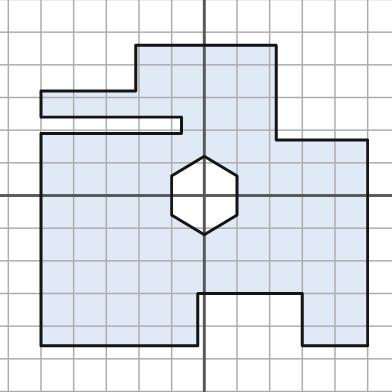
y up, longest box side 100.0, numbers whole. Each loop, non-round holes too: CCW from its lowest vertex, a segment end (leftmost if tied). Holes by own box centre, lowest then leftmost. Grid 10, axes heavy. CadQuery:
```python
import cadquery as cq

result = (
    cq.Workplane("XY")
    .moveTo(-50.0, -46.0)
    .lineTo(-2.0, -46.0)
    .lineTo(-2.0, -30.0)
    .lineTo(30.0, -30.0)
    .lineTo(30.0, -46.0)
    .lineTo(50.0, -46.0)
    .lineTo(50.0, 17.0)
    .lineTo(22.0, 17.0)
    .lineTo(22.0, 46.0)
    .lineTo(-21.0, 46.0)
    .lineTo(-21.0, 32.0)
    .lineTo(-50.0, 32.0)
    .lineTo(-50.0, 24.0)
    .lineTo(-7.0, 24.0)
    .lineTo(-7.0, 19.0)
    .lineTo(-50.0, 19.0)
    .close()
    .moveTo(0.0, -12.0)
    .lineTo(10.0, -6.0)
    .lineTo(10.0, 6.0)
    .lineTo(0.0, 12.0)
    .lineTo(-10.0, 6.0)
    .lineTo(-10.0, -6.0)
    .close()
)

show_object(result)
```